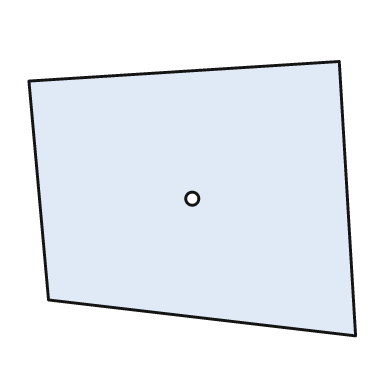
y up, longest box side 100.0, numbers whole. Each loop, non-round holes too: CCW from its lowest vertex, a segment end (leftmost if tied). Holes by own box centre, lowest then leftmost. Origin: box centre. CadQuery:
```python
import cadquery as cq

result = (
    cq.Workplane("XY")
    .moveTo(50.0, -42.0)
    .lineTo(45.0, 42.0)
    .lineTo(-50.0, 36.0)
    .lineTo(-44.0, -31.0)
    .close()
    .moveTo(0.0, 0.0)
    .circle(2.0)
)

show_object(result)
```